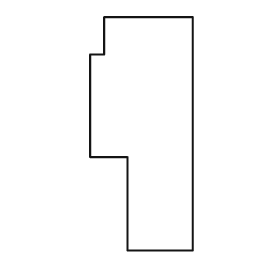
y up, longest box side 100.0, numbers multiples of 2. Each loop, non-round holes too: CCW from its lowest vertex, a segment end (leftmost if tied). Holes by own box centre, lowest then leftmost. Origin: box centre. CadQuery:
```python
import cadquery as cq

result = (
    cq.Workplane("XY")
    .moveTo(-6.0, -50.0)
    .lineTo(22.0, -50.0)
    .lineTo(22.0, 50.0)
    .lineTo(-16.0, 50.0)
    .lineTo(-16.0, 34.0)
    .lineTo(-22.0, 34.0)
    .lineTo(-22.0, -10.0)
    .lineTo(-6.0, -10.0)
    .close()
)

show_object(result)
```